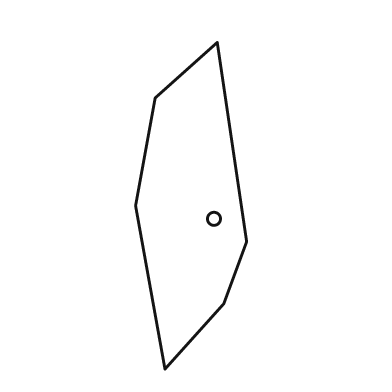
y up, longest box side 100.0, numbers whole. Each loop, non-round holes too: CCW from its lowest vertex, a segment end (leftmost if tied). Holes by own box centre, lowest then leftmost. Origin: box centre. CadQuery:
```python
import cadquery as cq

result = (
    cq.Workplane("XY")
    .moveTo(-8.0, -50.0)
    .lineTo(10.0, -30.0)
    .lineTo(17.0, -11.0)
    .lineTo(8.0, 50.0)
    .lineTo(-11.0, 33.0)
    .lineTo(-17.0, 0.0)
    .close()
    .moveTo(7.0, -4.0)
    .circle(2.0)
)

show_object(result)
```